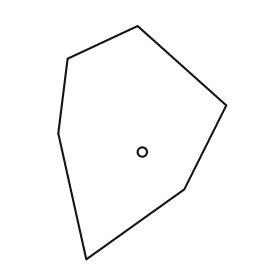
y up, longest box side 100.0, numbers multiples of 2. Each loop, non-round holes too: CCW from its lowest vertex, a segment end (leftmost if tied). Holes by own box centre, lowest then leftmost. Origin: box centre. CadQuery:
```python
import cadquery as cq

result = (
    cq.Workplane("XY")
    .moveTo(-24.0, -50.0)
    .lineTo(18.0, -20.0)
    .lineTo(36.0, 16.0)
    .lineTo(-2.0, 50.0)
    .lineTo(-32.0, 36.0)
    .lineTo(-36.0, 4.0)
    .close()
    .moveTo(0.0, -4.0)
    .circle(2.0)
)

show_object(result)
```